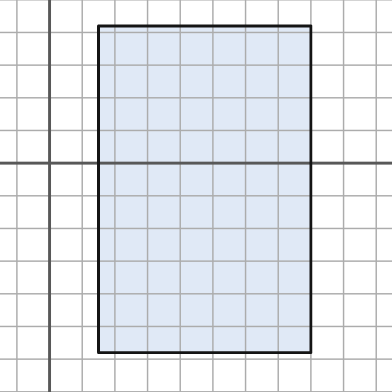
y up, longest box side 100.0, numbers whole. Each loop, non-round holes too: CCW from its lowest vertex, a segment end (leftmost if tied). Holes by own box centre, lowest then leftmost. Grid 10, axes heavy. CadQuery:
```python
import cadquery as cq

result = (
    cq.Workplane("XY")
    .moveTo(15.0, -58.0)
    .lineTo(80.0, -58.0)
    .lineTo(80.0, 42.0)
    .lineTo(15.0, 42.0)
    .close()
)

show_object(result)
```